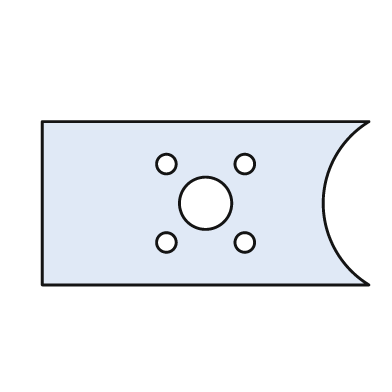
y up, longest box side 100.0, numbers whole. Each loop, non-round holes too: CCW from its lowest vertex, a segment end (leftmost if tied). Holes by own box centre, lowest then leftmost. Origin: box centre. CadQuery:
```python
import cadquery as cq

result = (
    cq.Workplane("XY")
    .moveTo(-50.0, -25.0)
    .lineTo(50.0, -25.0)
    .threePointArc((36.0, 0.0), (50.0, 25.0))
    .lineTo(-50.0, 25.0)
    .close()
    .moveTo(-12.0, -12.0)
    .circle(3.0)
    .moveTo(12.0, -12.0)
    .circle(3.0)
    .moveTo(0.0, 0.0)
    .circle(8.0)
    .moveTo(-12.0, 12.0)
    .circle(3.0)
    .moveTo(12.0, 12.0)
    .circle(3.0)
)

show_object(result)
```